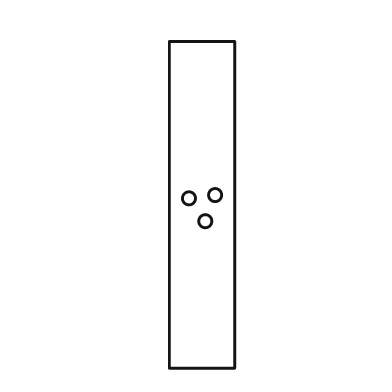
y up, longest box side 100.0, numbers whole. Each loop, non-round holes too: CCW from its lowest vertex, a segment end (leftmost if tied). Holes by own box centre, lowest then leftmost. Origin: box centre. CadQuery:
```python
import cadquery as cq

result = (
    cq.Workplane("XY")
    .moveTo(-10.0, -50.0)
    .lineTo(10.0, -50.0)
    .lineTo(10.0, 50.0)
    .lineTo(-10.0, 50.0)
    .close()
    .moveTo(1.0, -5.0)
    .circle(2.0)
    .moveTo(-4.0, 2.0)
    .circle(2.0)
    .moveTo(4.0, 3.0)
    .circle(2.0)
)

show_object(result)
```